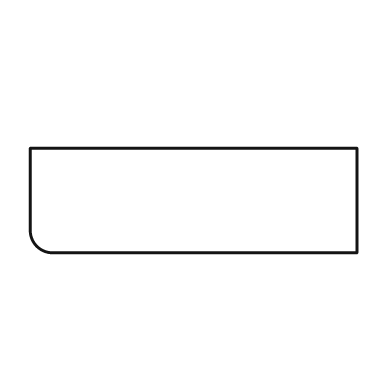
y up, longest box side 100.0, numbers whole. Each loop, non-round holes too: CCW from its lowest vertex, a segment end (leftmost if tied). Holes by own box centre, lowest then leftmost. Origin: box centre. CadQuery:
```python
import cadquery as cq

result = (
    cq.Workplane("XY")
    .moveTo(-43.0, -16.0)
    .lineTo(50.0, -16.0)
    .lineTo(50.0, 16.0)
    .lineTo(-50.0, 16.0)
    .lineTo(-50.0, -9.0)
    .threePointArc((-48.0, -14.0), (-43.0, -16.0))
    .close()
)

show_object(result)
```